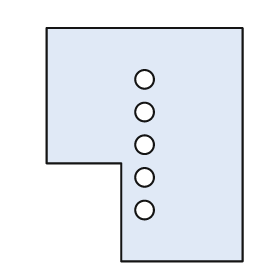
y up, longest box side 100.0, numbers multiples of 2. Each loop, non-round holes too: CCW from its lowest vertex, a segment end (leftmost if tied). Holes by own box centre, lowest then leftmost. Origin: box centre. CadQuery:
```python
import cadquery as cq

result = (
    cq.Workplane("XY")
    .moveTo(-10.0, -50.0)
    .lineTo(42.0, -50.0)
    .lineTo(42.0, 50.0)
    .lineTo(-42.0, 50.0)
    .lineTo(-42.0, -8.0)
    .lineTo(-10.0, -8.0)
    .close()
    .moveTo(0.0, -28.0)
    .circle(4.0)
    .moveTo(0.0, -14.0)
    .circle(4.0)
    .moveTo(0.0, 0.0)
    .circle(4.0)
    .moveTo(0.0, 14.0)
    .circle(4.0)
    .moveTo(0.0, 28.0)
    .circle(4.0)
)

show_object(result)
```